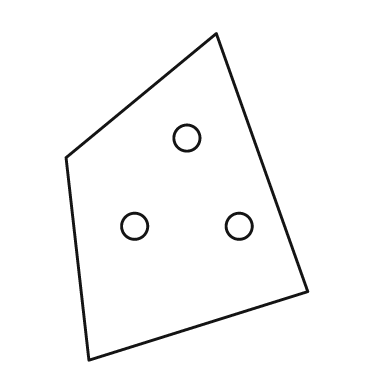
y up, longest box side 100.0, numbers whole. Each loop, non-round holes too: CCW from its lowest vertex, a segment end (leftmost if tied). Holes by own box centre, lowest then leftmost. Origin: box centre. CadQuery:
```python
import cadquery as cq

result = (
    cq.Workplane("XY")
    .moveTo(-30.0, -50.0)
    .lineTo(37.0, -29.0)
    .lineTo(9.0, 50.0)
    .lineTo(-37.0, 12.0)
    .close()
    .moveTo(-16.0, -9.0)
    .circle(4.0)
    .moveTo(16.0, -9.0)
    .circle(4.0)
    .moveTo(0.0, 18.0)
    .circle(4.0)
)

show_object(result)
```